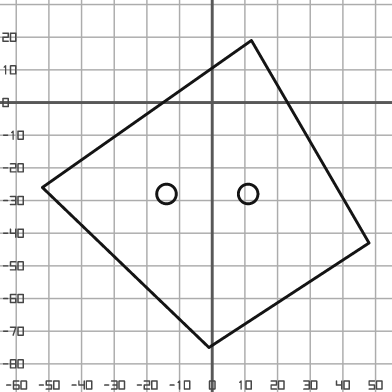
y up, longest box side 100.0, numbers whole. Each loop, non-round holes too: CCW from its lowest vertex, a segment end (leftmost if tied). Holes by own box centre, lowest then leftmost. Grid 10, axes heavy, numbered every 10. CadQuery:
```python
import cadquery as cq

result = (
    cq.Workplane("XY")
    .moveTo(-1.0, -75.0)
    .lineTo(48.0, -43.0)
    .lineTo(12.0, 19.0)
    .lineTo(-52.0, -26.0)
    .close()
    .moveTo(-14.0, -28.0)
    .circle(3.0)
    .moveTo(11.0, -28.0)
    .circle(3.0)
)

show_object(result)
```